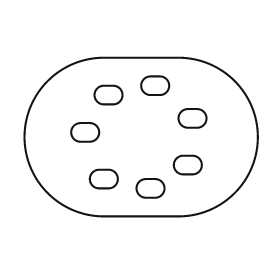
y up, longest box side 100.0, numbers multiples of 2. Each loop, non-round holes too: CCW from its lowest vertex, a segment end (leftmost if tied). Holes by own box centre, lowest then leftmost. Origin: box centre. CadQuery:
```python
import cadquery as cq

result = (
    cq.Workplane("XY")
    .moveTo(-16.0, -34.0)
    .lineTo(16.0, -34.0)
    .threePointArc((50.0, 0.0), (16.0, 34.0))
    .lineTo(-16.0, 34.0)
    .threePointArc((-50.0, 0.0), (-16.0, -34.0))
    .close()
    .moveTo(2.0, -26.0)
    .lineTo(6.0, -26.0)
    .threePointArc((10.0, -22.0), (6.0, -18.0))
    .lineTo(2.0, -18.0)
    .threePointArc((-2.0, -22.0), (2.0, -26.0))
    .close()
    .moveTo(-18.0, -22.0)
    .lineTo(-14.0, -22.0)
    .threePointArc((-10.0, -18.0), (-14.0, -14.0))
    .lineTo(-18.0, -14.0)
    .threePointArc((-22.0, -18.0), (-18.0, -22.0))
    .close()
    .moveTo(18.0, -16.0)
    .lineTo(22.0, -16.0)
    .threePointArc((26.0, -12.0), (22.0, -8.0))
    .lineTo(18.0, -8.0)
    .threePointArc((14.0, -12.0), (18.0, -16.0))
    .close()
    .moveTo(-26.0, -2.0)
    .lineTo(-22.0, -2.0)
    .threePointArc((-18.0, 2.0), (-22.0, 6.0))
    .lineTo(-26.0, 6.0)
    .threePointArc((-30.0, 2.0), (-26.0, -2.0))
    .close()
    .moveTo(20.0, 4.0)
    .lineTo(24.0, 4.0)
    .threePointArc((28.0, 8.0), (24.0, 12.0))
    .lineTo(20.0, 12.0)
    .threePointArc((16.0, 8.0), (20.0, 4.0))
    .close()
    .moveTo(-16.0, 14.0)
    .lineTo(-12.0, 14.0)
    .threePointArc((-8.0, 18.0), (-12.0, 22.0))
    .lineTo(-16.0, 22.0)
    .threePointArc((-20.0, 18.0), (-16.0, 14.0))
    .close()
    .moveTo(4.0, 18.0)
    .lineTo(8.0, 18.0)
    .threePointArc((12.0, 22.0), (8.0, 26.0))
    .lineTo(4.0, 26.0)
    .threePointArc((0.0, 22.0), (4.0, 18.0))
    .close()
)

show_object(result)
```